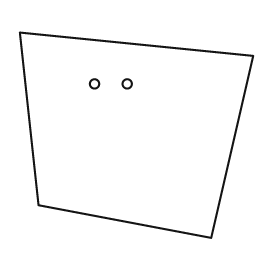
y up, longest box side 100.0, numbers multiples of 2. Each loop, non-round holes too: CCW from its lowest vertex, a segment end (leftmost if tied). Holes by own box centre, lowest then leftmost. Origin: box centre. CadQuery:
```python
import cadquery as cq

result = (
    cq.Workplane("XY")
    .moveTo(32.0, -44.0)
    .lineTo(50.0, 34.0)
    .lineTo(-50.0, 44.0)
    .lineTo(-42.0, -30.0)
    .close()
    .moveTo(-18.0, 22.0)
    .circle(2.0)
    .moveTo(-4.0, 22.0)
    .circle(2.0)
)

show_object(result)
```